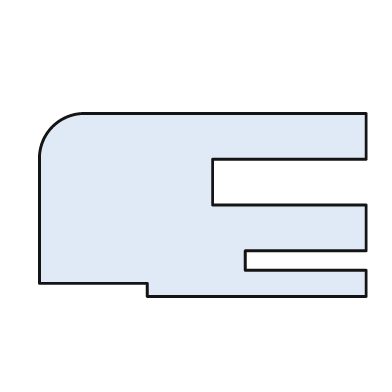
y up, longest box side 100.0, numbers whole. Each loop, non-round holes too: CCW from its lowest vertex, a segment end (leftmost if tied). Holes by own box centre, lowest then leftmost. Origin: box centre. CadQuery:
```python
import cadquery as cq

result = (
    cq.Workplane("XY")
    .moveTo(-17.0, -28.0)
    .lineTo(50.0, -28.0)
    .lineTo(50.0, -20.0)
    .lineTo(13.0, -20.0)
    .lineTo(13.0, -14.0)
    .lineTo(50.0, -14.0)
    .lineTo(50.0, 0.0)
    .lineTo(3.0, 0.0)
    .lineTo(3.0, 14.0)
    .lineTo(50.0, 14.0)
    .lineTo(50.0, 28.0)
    .lineTo(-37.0, 28.0)
    .threePointArc((-46.0, 24.0), (-50.0, 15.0))
    .lineTo(-50.0, -24.0)
    .lineTo(-17.0, -24.0)
    .close()
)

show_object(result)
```